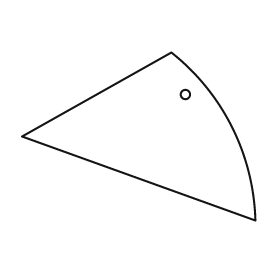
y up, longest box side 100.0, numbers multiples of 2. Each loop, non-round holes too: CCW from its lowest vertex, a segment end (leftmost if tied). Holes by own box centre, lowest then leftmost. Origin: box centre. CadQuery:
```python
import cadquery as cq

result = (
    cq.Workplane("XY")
    .moveTo(50.0, -36.0)
    .threePointArc((40.0, 4.0), (14.0, 36.0))
    .lineTo(-50.0, 0.0)
    .close()
    .moveTo(20.0, 18.0)
    .circle(2.0)
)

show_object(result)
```